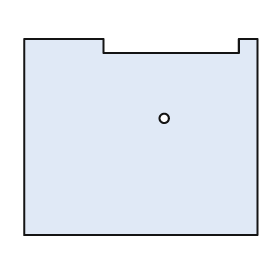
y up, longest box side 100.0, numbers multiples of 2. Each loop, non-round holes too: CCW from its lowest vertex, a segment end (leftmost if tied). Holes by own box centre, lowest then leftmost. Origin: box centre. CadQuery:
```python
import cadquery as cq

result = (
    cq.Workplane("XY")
    .moveTo(-50.0, -42.0)
    .lineTo(50.0, -42.0)
    .lineTo(50.0, 42.0)
    .lineTo(42.0, 42.0)
    .lineTo(42.0, 36.0)
    .lineTo(-16.0, 36.0)
    .lineTo(-16.0, 42.0)
    .lineTo(-50.0, 42.0)
    .close()
    .moveTo(10.0, 8.0)
    .circle(2.0)
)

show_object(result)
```